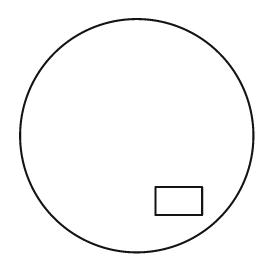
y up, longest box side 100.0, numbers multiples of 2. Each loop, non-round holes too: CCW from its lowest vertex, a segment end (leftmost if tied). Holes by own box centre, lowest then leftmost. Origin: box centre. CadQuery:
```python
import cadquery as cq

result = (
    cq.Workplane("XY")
    .moveTo(0.0, 0.0)
    .circle(50.0)
    .moveTo(8.0, -34.0)
    .lineTo(28.0, -34.0)
    .lineTo(28.0, -22.0)
    .lineTo(8.0, -22.0)
    .close()
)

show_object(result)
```